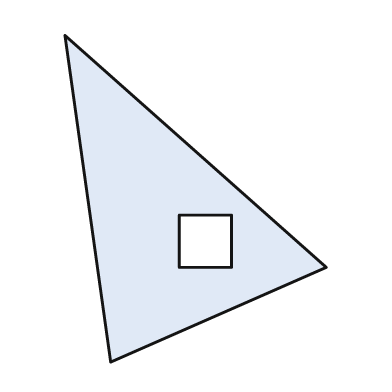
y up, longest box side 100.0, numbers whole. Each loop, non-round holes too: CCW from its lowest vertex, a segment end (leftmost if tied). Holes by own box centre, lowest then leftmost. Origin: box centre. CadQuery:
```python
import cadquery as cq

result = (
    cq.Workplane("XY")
    .moveTo(-26.0, -50.0)
    .lineTo(40.0, -21.0)
    .lineTo(-40.0, 50.0)
    .close()
    .moveTo(-5.0, -21.0)
    .lineTo(11.0, -21.0)
    .lineTo(11.0, -5.0)
    .lineTo(-5.0, -5.0)
    .close()
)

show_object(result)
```